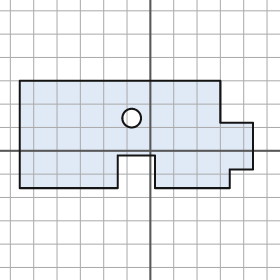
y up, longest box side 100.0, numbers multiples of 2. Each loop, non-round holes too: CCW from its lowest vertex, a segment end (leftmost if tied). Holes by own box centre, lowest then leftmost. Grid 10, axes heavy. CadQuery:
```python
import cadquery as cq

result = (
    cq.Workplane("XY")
    .moveTo(-56.0, -16.0)
    .lineTo(-14.0, -16.0)
    .lineTo(-14.0, -2.0)
    .lineTo(2.0, -2.0)
    .lineTo(2.0, -16.0)
    .lineTo(34.0, -16.0)
    .lineTo(34.0, -8.0)
    .lineTo(44.0, -8.0)
    .lineTo(44.0, 12.0)
    .lineTo(30.0, 12.0)
    .lineTo(30.0, 30.0)
    .lineTo(-56.0, 30.0)
    .close()
    .moveTo(-8.0, 14.0)
    .circle(4.0)
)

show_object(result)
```